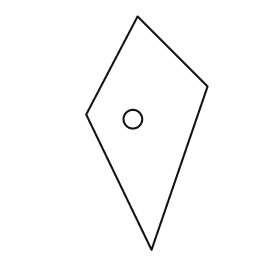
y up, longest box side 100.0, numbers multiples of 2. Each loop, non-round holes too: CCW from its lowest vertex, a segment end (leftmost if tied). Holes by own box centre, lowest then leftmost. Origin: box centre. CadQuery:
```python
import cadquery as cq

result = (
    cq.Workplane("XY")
    .moveTo(2.0, -50.0)
    .lineTo(26.0, 20.0)
    .lineTo(-4.0, 50.0)
    .lineTo(-26.0, 8.0)
    .close()
    .moveTo(-6.0, 6.0)
    .circle(4.0)
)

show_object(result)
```